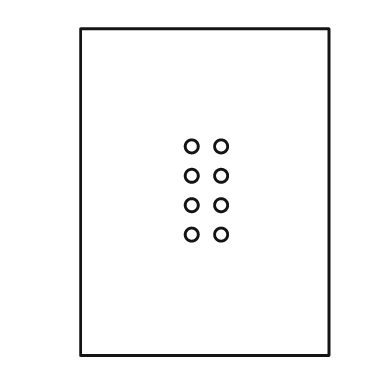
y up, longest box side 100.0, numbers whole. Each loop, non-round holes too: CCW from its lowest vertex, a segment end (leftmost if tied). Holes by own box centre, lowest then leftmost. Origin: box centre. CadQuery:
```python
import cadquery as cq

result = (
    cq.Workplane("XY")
    .moveTo(-38.0, -50.0)
    .lineTo(38.0, -50.0)
    .lineTo(38.0, 50.0)
    .lineTo(-38.0, 50.0)
    .close()
    .moveTo(-4.0, -13.0)
    .circle(2.0)
    .moveTo(5.0, -13.0)
    .circle(2.0)
    .moveTo(-4.0, -4.0)
    .circle(2.0)
    .moveTo(5.0, -4.0)
    .circle(2.0)
    .moveTo(-4.0, 5.0)
    .circle(2.0)
    .moveTo(5.0, 5.0)
    .circle(2.0)
    .moveTo(-4.0, 14.0)
    .circle(2.0)
    .moveTo(5.0, 14.0)
    .circle(2.0)
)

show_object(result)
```